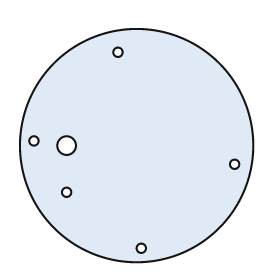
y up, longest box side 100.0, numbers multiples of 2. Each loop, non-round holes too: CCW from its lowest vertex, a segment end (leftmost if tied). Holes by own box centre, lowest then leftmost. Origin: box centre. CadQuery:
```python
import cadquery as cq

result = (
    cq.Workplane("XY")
    .moveTo(0.0, 0.0)
    .circle(50.0)
    .moveTo(2.0, -44.0)
    .circle(2.0)
    .moveTo(-30.0, -20.0)
    .circle(2.0)
    .moveTo(42.0, -8.0)
    .circle(2.0)
    .moveTo(-30.0, 0.0)
    .circle(4.0)
    .moveTo(-44.0, 2.0)
    .circle(2.0)
    .moveTo(-8.0, 40.0)
    .circle(2.0)
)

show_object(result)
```